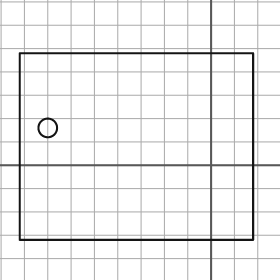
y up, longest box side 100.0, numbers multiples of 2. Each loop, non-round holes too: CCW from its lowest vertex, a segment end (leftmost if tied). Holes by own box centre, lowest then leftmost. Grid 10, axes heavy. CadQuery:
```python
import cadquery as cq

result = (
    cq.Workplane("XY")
    .moveTo(-82.0, -32.0)
    .lineTo(18.0, -32.0)
    .lineTo(18.0, 48.0)
    .lineTo(-82.0, 48.0)
    .close()
    .moveTo(-70.0, 16.0)
    .circle(4.0)
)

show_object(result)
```